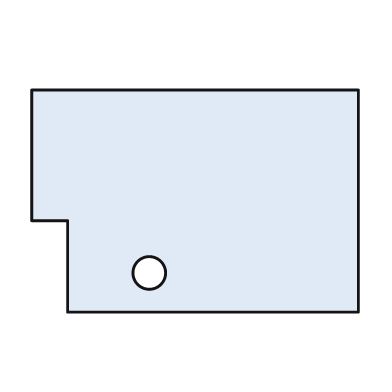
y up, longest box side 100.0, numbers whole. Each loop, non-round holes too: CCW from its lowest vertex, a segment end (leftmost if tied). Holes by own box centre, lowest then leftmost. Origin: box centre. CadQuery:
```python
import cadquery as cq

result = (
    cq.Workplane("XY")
    .moveTo(-39.0, -34.0)
    .lineTo(50.0, -34.0)
    .lineTo(50.0, 34.0)
    .lineTo(-50.0, 34.0)
    .lineTo(-50.0, -6.0)
    .lineTo(-39.0, -6.0)
    .close()
    .moveTo(-14.0, -22.0)
    .circle(5.0)
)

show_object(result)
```